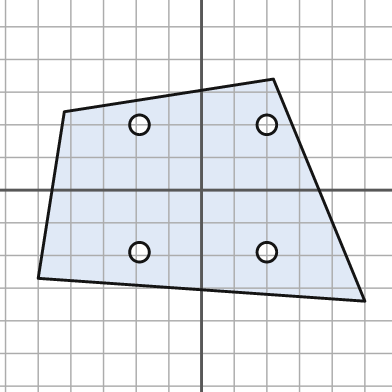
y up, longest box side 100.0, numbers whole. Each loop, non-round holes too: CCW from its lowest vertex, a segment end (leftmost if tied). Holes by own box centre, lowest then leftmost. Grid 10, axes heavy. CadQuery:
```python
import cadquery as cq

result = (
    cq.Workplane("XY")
    .moveTo(50.0, -34.0)
    .lineTo(22.0, 34.0)
    .lineTo(-42.0, 24.0)
    .lineTo(-50.0, -27.0)
    .close()
    .moveTo(-19.0, -19.0)
    .circle(3.0)
    .moveTo(20.0, -19.0)
    .circle(3.0)
    .moveTo(-19.0, 20.0)
    .circle(3.0)
    .moveTo(20.0, 20.0)
    .circle(3.0)
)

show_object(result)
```